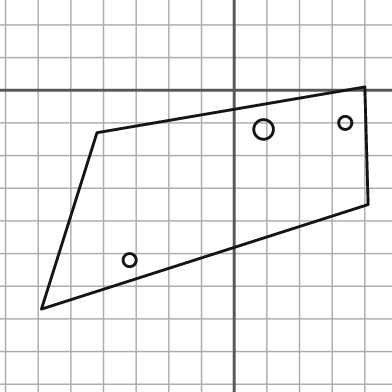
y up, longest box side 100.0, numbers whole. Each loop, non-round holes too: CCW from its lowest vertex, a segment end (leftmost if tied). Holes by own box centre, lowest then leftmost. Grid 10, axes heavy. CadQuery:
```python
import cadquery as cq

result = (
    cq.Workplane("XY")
    .moveTo(-59.0, -67.0)
    .lineTo(41.0, -35.0)
    .lineTo(40.0, 1.0)
    .lineTo(-42.0, -13.0)
    .close()
    .moveTo(-32.0, -52.0)
    .circle(2.0)
    .moveTo(9.0, -12.0)
    .circle(3.0)
    .moveTo(34.0, -10.0)
    .circle(2.0)
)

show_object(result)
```